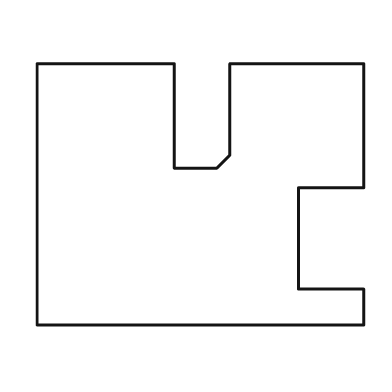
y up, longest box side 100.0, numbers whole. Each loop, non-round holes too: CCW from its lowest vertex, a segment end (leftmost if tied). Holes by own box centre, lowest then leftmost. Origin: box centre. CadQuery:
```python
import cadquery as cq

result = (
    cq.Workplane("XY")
    .moveTo(-50.0, -40.0)
    .lineTo(50.0, -40.0)
    .lineTo(50.0, -29.0)
    .lineTo(30.0, -29.0)
    .lineTo(30.0, 2.0)
    .lineTo(50.0, 2.0)
    .lineTo(50.0, 40.0)
    .lineTo(9.0, 40.0)
    .lineTo(9.0, 12.0)
    .lineTo(5.0, 8.0)
    .lineTo(-8.0, 8.0)
    .lineTo(-8.0, 40.0)
    .lineTo(-50.0, 40.0)
    .close()
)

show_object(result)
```